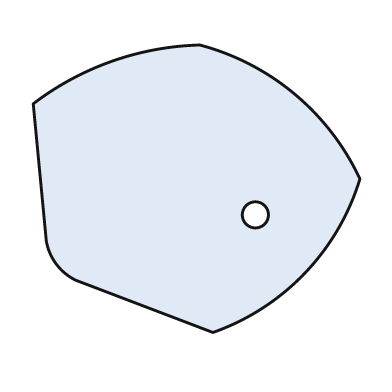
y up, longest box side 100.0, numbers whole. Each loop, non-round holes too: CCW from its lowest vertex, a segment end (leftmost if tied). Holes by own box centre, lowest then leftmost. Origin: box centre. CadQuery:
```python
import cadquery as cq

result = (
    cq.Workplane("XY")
    .moveTo(5.0, -44.0)
    .threePointArc((33.0, -26.0), (50.0, 3.0))
    .threePointArc((30.0, 29.0), (1.0, 44.0))
    .threePointArc((-26.0, 39.0), (-50.0, 26.0))
    .lineTo(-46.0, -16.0)
    .threePointArc((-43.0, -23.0), (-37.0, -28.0))
    .close()
    .moveTo(18.0, -8.0)
    .circle(4.0)
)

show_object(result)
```